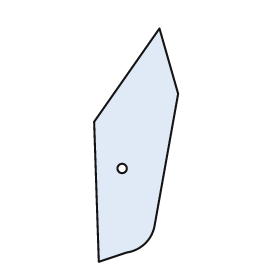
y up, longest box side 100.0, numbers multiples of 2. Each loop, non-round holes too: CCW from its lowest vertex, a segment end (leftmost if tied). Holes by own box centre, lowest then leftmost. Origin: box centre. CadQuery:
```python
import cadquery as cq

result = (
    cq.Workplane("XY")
    .moveTo(-16.0, -50.0)
    .lineTo(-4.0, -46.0)
    .threePointArc((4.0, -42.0), (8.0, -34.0))
    .lineTo(18.0, 22.0)
    .lineTo(10.0, 50.0)
    .lineTo(-18.0, 10.0)
    .close()
    .moveTo(-6.0, -10.0)
    .circle(2.0)
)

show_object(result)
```